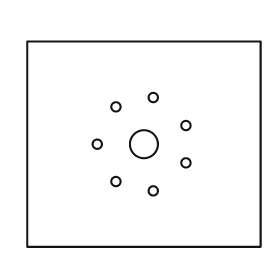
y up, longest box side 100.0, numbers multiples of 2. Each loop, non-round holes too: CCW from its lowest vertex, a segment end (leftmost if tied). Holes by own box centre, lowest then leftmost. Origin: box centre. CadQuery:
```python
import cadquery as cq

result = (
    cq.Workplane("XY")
    .moveTo(-50.0, -44.0)
    .lineTo(50.0, -44.0)
    .lineTo(50.0, 44.0)
    .lineTo(-50.0, 44.0)
    .close()
    .moveTo(4.0, -20.0)
    .circle(2.0)
    .moveTo(-12.0, -16.0)
    .circle(2.0)
    .moveTo(18.0, -8.0)
    .circle(2.0)
    .moveTo(-20.0, 0.0)
    .circle(2.0)
    .moveTo(0.0, 0.0)
    .circle(6.0)
    .moveTo(18.0, 8.0)
    .circle(2.0)
    .moveTo(-12.0, 16.0)
    .circle(2.0)
    .moveTo(4.0, 20.0)
    .circle(2.0)
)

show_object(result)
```